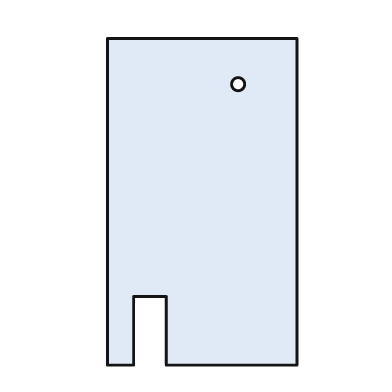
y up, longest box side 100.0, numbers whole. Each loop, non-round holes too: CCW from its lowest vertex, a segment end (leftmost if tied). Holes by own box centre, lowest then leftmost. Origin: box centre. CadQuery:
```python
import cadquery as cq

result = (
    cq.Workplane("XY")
    .moveTo(-29.0, -50.0)
    .lineTo(-21.0, -50.0)
    .lineTo(-21.0, -29.0)
    .lineTo(-11.0, -29.0)
    .lineTo(-11.0, -50.0)
    .lineTo(29.0, -50.0)
    .lineTo(29.0, 50.0)
    .lineTo(-29.0, 50.0)
    .close()
    .moveTo(11.0, 36.0)
    .circle(2.0)
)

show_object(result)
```